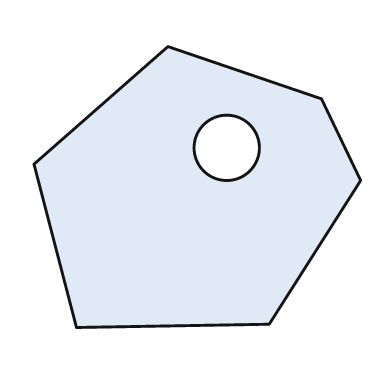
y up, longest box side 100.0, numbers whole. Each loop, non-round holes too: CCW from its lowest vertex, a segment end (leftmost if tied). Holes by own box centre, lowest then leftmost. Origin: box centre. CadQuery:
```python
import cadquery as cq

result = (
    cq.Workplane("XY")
    .moveTo(-37.0, -43.0)
    .lineTo(22.0, -42.0)
    .lineTo(50.0, 2.0)
    .lineTo(38.0, 27.0)
    .lineTo(-9.0, 43.0)
    .lineTo(-50.0, 7.0)
    .close()
    .moveTo(9.0, 12.0)
    .circle(10.0)
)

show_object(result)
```